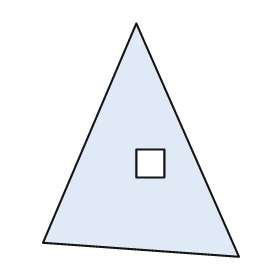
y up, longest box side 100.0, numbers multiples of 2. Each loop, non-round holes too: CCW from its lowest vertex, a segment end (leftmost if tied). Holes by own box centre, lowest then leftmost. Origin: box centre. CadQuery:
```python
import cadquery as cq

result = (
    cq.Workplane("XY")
    .moveTo(42.0, -50.0)
    .lineTo(-2.0, 50.0)
    .lineTo(-42.0, -44.0)
    .close()
    .moveTo(-2.0, -16.0)
    .lineTo(10.0, -16.0)
    .lineTo(10.0, -4.0)
    .lineTo(-2.0, -4.0)
    .close()
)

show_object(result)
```